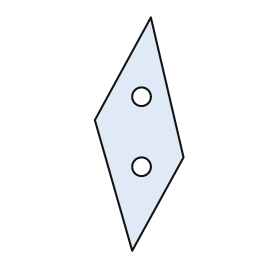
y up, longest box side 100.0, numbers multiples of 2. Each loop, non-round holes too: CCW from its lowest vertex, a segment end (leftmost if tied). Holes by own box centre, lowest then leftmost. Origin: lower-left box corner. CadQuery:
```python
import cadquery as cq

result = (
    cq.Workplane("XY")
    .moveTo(16.0, 0.0)
    .lineTo(38.0, 40.0)
    .lineTo(24.0, 100.0)
    .lineTo(0.0, 56.0)
    .close()
    .moveTo(20.0, 36.0)
    .circle(4.0)
    .moveTo(20.0, 66.0)
    .circle(4.0)
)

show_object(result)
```